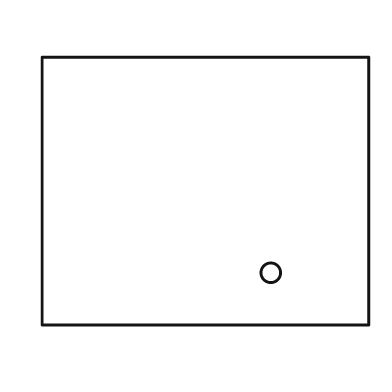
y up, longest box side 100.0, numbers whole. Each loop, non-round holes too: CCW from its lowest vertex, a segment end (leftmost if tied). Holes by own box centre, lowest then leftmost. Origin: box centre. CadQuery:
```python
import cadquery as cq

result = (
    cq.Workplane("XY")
    .moveTo(-50.0, -41.0)
    .lineTo(50.0, -41.0)
    .lineTo(50.0, 41.0)
    .lineTo(-50.0, 41.0)
    .close()
    .moveTo(20.0, -25.0)
    .circle(3.0)
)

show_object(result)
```